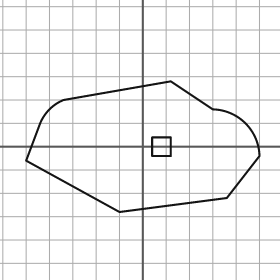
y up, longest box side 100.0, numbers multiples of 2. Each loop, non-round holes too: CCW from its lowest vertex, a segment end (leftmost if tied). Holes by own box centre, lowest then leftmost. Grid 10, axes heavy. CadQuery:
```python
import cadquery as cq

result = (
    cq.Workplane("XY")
    .moveTo(-10.0, -28.0)
    .lineTo(36.0, -22.0)
    .lineTo(50.0, -4.0)
    .threePointArc((44.0, 10.0), (30.0, 16.0))
    .lineTo(12.0, 28.0)
    .lineTo(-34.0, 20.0)
    .threePointArc((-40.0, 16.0), (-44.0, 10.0))
    .lineTo(-50.0, -6.0)
    .close()
    .moveTo(4.0, -4.0)
    .lineTo(12.0, -4.0)
    .lineTo(12.0, 4.0)
    .lineTo(4.0, 4.0)
    .close()
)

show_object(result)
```